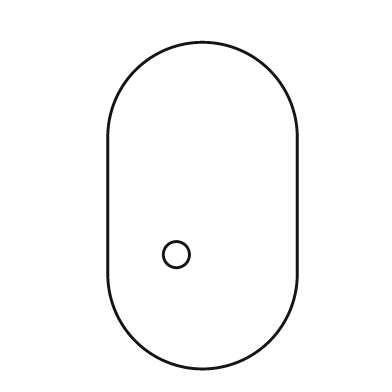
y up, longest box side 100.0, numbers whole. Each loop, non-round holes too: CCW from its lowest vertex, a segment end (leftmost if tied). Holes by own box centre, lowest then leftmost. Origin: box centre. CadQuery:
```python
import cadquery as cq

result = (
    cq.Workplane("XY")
    .moveTo(-29.0, -21.0)
    .threePointArc((0.0, -50.0), (29.0, -21.0))
    .lineTo(29.0, 21.0)
    .threePointArc((0.0, 50.0), (-29.0, 21.0))
    .close()
    .moveTo(-8.0, -15.0)
    .circle(4.0)
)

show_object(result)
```